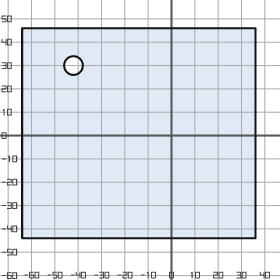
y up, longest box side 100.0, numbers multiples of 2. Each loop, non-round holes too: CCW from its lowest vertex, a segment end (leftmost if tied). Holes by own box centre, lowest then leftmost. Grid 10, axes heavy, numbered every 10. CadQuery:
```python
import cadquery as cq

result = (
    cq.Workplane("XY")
    .moveTo(-64.0, -44.0)
    .lineTo(36.0, -44.0)
    .lineTo(36.0, 46.0)
    .lineTo(-64.0, 46.0)
    .close()
    .moveTo(-42.0, 30.0)
    .circle(4.0)
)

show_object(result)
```